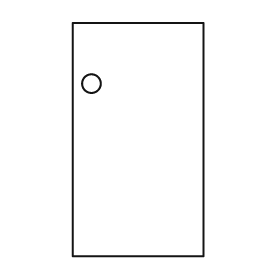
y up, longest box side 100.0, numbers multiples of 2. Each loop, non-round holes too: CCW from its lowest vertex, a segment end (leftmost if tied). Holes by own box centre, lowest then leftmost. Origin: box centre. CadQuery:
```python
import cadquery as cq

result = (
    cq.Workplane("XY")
    .moveTo(-28.0, -50.0)
    .lineTo(28.0, -50.0)
    .lineTo(28.0, 50.0)
    .lineTo(-28.0, 50.0)
    .close()
    .moveTo(-20.0, 24.0)
    .circle(4.0)
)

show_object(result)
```